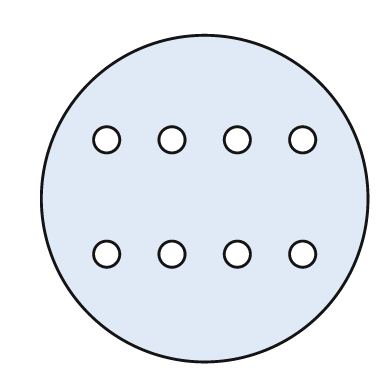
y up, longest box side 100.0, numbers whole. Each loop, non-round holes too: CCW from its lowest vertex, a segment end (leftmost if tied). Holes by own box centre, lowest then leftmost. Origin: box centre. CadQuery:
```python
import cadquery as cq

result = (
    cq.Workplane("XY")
    .moveTo(0.0, 0.0)
    .circle(50.0)
    .moveTo(-30.0, -17.0)
    .circle(4.0)
    .moveTo(-10.0, -17.0)
    .circle(4.0)
    .moveTo(10.0, -17.0)
    .circle(4.0)
    .moveTo(30.0, -17.0)
    .circle(4.0)
    .moveTo(-30.0, 18.0)
    .circle(4.0)
    .moveTo(-10.0, 18.0)
    .circle(4.0)
    .moveTo(10.0, 18.0)
    .circle(4.0)
    .moveTo(30.0, 18.0)
    .circle(4.0)
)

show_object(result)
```